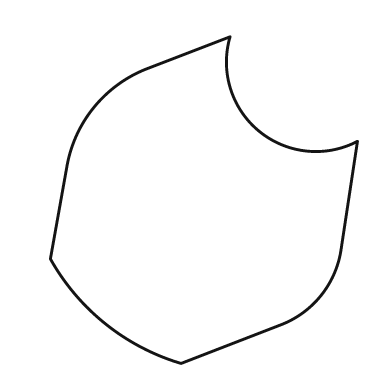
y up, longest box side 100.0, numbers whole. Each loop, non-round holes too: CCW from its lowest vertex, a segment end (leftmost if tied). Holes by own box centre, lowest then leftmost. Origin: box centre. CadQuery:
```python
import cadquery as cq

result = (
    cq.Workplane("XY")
    .moveTo(-7.0, -50.0)
    .lineTo(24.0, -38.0)
    .threePointArc((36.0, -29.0), (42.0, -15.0))
    .lineTo(47.0, 18.0)
    .threePointArc((17.0, 21.0), (8.0, 50.0))
    .lineTo(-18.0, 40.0)
    .threePointArc((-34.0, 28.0), (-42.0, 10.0))
    .lineTo(-47.0, -18.0)
    .threePointArc((-30.0, -38.0), (-7.0, -50.0))
    .close()
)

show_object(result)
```